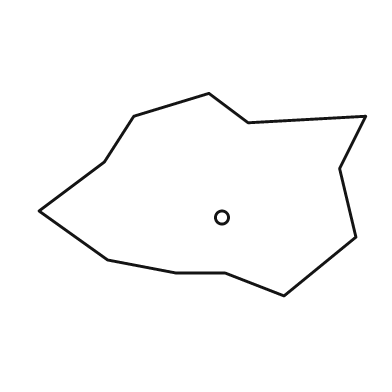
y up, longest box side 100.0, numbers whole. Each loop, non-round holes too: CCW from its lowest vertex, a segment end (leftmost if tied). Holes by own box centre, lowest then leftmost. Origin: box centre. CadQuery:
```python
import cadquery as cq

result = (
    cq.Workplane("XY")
    .moveTo(25.0, -31.0)
    .lineTo(47.0, -13.0)
    .lineTo(42.0, 8.0)
    .lineTo(50.0, 24.0)
    .lineTo(14.0, 22.0)
    .lineTo(2.0, 31.0)
    .lineTo(-21.0, 24.0)
    .lineTo(-30.0, 10.0)
    .lineTo(-50.0, -5.0)
    .lineTo(-29.0, -20.0)
    .lineTo(-8.0, -24.0)
    .lineTo(7.0, -24.0)
    .close()
    .moveTo(6.0, -7.0)
    .circle(2.0)
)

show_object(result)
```